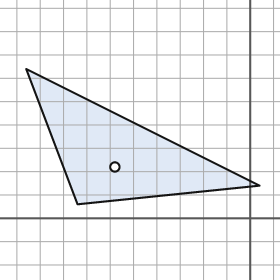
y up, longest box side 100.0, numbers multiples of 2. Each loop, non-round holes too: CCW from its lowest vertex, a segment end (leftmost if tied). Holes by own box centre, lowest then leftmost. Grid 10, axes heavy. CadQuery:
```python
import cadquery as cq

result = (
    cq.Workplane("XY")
    .moveTo(-74.0, 6.0)
    .lineTo(4.0, 14.0)
    .lineTo(-96.0, 64.0)
    .close()
    .moveTo(-58.0, 22.0)
    .circle(2.0)
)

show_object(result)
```